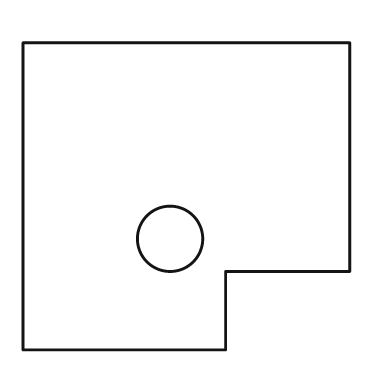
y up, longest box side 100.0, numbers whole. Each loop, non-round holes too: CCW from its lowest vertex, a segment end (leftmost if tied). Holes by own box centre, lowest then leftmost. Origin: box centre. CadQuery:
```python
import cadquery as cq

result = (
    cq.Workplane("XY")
    .moveTo(-50.0, -47.0)
    .lineTo(12.0, -47.0)
    .lineTo(12.0, -23.0)
    .lineTo(50.0, -23.0)
    .lineTo(50.0, 47.0)
    .lineTo(-50.0, 47.0)
    .close()
    .moveTo(-5.0, -13.0)
    .circle(10.0)
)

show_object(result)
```